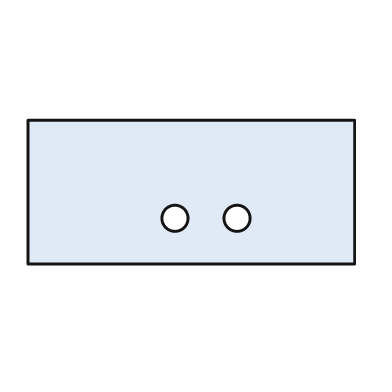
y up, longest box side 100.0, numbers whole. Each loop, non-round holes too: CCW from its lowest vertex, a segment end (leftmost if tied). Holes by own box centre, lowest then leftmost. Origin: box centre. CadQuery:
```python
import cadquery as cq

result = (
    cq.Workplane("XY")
    .moveTo(-50.0, -22.0)
    .lineTo(50.0, -22.0)
    .lineTo(50.0, 22.0)
    .lineTo(-50.0, 22.0)
    .close()
    .moveTo(-5.0, -8.0)
    .circle(4.0)
    .moveTo(14.0, -8.0)
    .circle(4.0)
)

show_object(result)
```